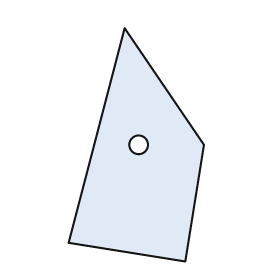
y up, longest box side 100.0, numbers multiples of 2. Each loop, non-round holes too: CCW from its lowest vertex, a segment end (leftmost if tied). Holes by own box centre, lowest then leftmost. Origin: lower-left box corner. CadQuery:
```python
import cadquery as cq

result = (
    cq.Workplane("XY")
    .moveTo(50.0, 0.0)
    .lineTo(58.0, 50.0)
    .lineTo(24.0, 100.0)
    .lineTo(0.0, 8.0)
    .close()
    .moveTo(30.0, 50.0)
    .circle(4.0)
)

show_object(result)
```